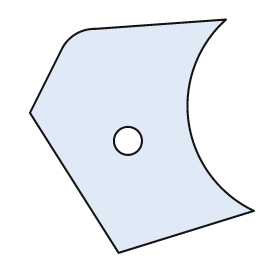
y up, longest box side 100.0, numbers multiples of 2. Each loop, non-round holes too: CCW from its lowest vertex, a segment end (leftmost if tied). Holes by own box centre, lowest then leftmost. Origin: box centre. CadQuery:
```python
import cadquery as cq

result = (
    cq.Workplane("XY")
    .moveTo(-10.0, -50.0)
    .lineTo(48.0, -32.0)
    .threePointArc((20.0, 6.0), (36.0, 50.0))
    .lineTo(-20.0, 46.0)
    .threePointArc((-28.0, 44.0), (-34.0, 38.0))
    .lineTo(-48.0, 10.0)
    .close()
    .moveTo(-6.0, -2.0)
    .circle(6.0)
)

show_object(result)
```